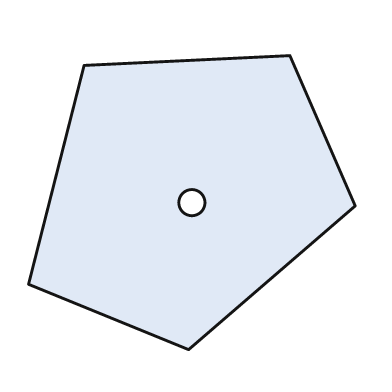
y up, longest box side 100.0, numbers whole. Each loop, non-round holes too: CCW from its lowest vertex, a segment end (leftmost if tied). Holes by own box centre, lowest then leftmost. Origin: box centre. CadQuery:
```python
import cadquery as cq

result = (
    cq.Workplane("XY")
    .moveTo(-1.0, -45.0)
    .lineTo(50.0, -1.0)
    .lineTo(30.0, 45.0)
    .lineTo(-33.0, 42.0)
    .lineTo(-50.0, -25.0)
    .close()
    .moveTo(0.0, 0.0)
    .circle(4.0)
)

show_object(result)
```